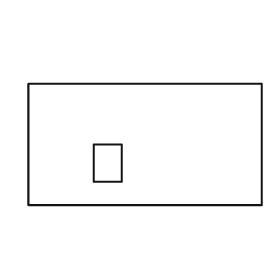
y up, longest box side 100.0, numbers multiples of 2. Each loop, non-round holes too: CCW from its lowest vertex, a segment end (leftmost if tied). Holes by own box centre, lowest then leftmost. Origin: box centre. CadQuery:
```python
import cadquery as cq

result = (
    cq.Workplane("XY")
    .moveTo(-50.0, -26.0)
    .lineTo(50.0, -26.0)
    .lineTo(50.0, 26.0)
    .lineTo(-50.0, 26.0)
    .close()
    .moveTo(-22.0, -16.0)
    .lineTo(-10.0, -16.0)
    .lineTo(-10.0, 0.0)
    .lineTo(-22.0, 0.0)
    .close()
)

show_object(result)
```